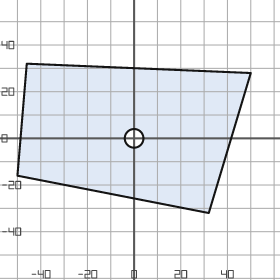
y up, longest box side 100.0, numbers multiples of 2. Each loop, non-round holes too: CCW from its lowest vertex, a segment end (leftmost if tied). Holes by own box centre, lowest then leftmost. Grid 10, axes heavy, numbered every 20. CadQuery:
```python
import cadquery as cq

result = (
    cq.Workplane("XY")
    .moveTo(32.0, -32.0)
    .lineTo(50.0, 28.0)
    .lineTo(-46.0, 32.0)
    .lineTo(-50.0, -16.0)
    .close()
    .moveTo(0.0, 0.0)
    .circle(4.0)
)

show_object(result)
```